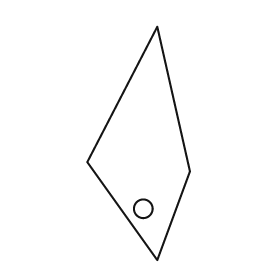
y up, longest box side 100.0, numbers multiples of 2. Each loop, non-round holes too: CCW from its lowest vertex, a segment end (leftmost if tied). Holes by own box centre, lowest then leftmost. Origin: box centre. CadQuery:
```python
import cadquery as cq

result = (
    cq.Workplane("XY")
    .moveTo(8.0, -50.0)
    .lineTo(22.0, -12.0)
    .lineTo(8.0, 50.0)
    .lineTo(-22.0, -8.0)
    .close()
    .moveTo(2.0, -28.0)
    .circle(4.0)
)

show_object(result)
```